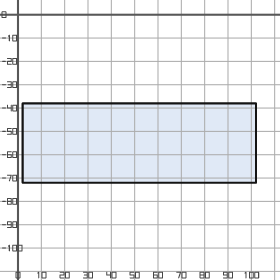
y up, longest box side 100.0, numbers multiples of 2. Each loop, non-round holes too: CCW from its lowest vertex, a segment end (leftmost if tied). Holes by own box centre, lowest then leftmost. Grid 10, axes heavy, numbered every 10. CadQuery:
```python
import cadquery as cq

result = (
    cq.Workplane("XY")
    .moveTo(2.0, -72.0)
    .lineTo(102.0, -72.0)
    .lineTo(102.0, -38.0)
    .lineTo(2.0, -38.0)
    .close()
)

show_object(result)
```